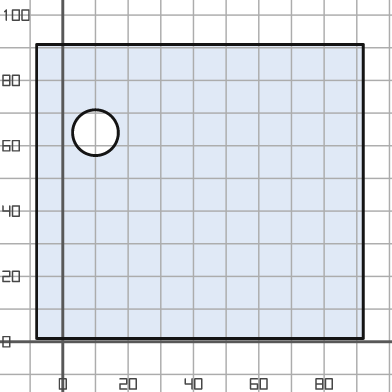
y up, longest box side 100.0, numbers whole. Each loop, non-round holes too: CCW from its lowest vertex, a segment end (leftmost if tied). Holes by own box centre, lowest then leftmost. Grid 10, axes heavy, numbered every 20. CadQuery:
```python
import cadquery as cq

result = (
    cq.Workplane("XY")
    .moveTo(-8.0, 1.0)
    .lineTo(92.0, 1.0)
    .lineTo(92.0, 91.0)
    .lineTo(-8.0, 91.0)
    .close()
    .moveTo(10.0, 64.0)
    .circle(7.0)
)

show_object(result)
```